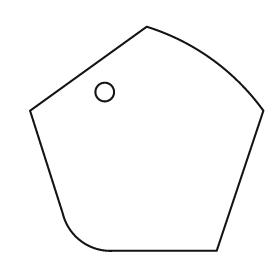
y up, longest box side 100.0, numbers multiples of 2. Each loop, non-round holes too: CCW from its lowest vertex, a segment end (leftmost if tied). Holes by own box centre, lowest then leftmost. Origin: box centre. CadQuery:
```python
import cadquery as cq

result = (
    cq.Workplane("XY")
    .moveTo(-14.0, -48.0)
    .lineTo(30.0, -48.0)
    .lineTo(50.0, 12.0)
    .threePointArc((28.0, 34.0), (0.0, 48.0))
    .lineTo(-50.0, 12.0)
    .lineTo(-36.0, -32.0)
    .threePointArc((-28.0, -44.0), (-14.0, -48.0))
    .close()
    .moveTo(-18.0, 20.0)
    .circle(4.0)
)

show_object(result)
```